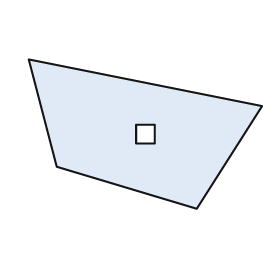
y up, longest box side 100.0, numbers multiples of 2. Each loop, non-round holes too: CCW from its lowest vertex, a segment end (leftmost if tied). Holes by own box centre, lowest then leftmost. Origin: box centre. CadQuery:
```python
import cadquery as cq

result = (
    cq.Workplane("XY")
    .moveTo(22.0, -32.0)
    .lineTo(50.0, 12.0)
    .lineTo(-50.0, 32.0)
    .lineTo(-38.0, -14.0)
    .close()
    .moveTo(-4.0, -4.0)
    .lineTo(4.0, -4.0)
    .lineTo(4.0, 4.0)
    .lineTo(-4.0, 4.0)
    .close()
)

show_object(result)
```